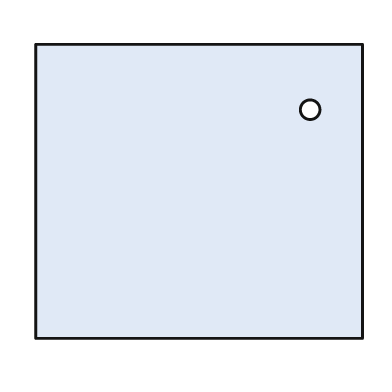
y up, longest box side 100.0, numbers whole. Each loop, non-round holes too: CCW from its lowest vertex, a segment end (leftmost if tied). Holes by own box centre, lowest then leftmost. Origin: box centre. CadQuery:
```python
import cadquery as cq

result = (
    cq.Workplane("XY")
    .moveTo(-50.0, -45.0)
    .lineTo(50.0, -45.0)
    .lineTo(50.0, 45.0)
    .lineTo(-50.0, 45.0)
    .close()
    .moveTo(34.0, 25.0)
    .circle(3.0)
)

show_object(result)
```